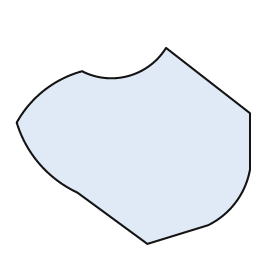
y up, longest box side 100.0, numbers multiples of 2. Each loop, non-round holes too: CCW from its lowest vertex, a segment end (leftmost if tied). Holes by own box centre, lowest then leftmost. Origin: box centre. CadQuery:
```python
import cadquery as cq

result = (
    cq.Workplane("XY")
    .moveTo(6.0, -42.0)
    .lineTo(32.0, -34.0)
    .threePointArc((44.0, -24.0), (50.0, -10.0))
    .lineTo(50.0, 14.0)
    .lineTo(14.0, 42.0)
    .threePointArc((-2.0, 30.0), (-22.0, 32.0))
    .threePointArc((-38.0, 24.0), (-50.0, 10.0))
    .threePointArc((-40.0, -8.0), (-24.0, -20.0))
    .close()
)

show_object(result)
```